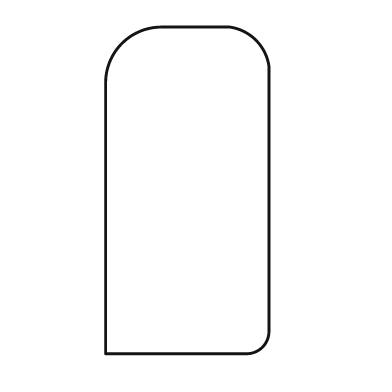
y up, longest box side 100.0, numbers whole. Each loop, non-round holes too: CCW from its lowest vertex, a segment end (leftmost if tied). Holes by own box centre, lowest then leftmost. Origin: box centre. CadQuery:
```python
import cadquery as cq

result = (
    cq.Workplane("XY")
    .moveTo(-25.0, -50.0)
    .lineTo(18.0, -50.0)
    .threePointArc((23.0, -48.0), (25.0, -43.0))
    .lineTo(25.0, 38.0)
    .threePointArc((21.0, 46.0), (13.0, 50.0))
    .lineTo(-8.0, 50.0)
    .threePointArc((-20.0, 45.0), (-25.0, 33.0))
    .close()
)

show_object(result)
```